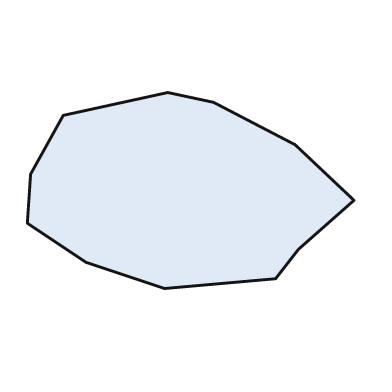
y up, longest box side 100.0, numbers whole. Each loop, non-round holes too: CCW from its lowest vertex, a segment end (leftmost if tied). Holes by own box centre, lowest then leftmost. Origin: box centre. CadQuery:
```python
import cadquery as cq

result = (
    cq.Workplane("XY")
    .moveTo(-8.0, -30.0)
    .lineTo(26.0, -27.0)
    .lineTo(33.0, -18.0)
    .lineTo(50.0, -3.0)
    .lineTo(32.0, 14.0)
    .lineTo(7.0, 27.0)
    .lineTo(-7.0, 30.0)
    .lineTo(-39.0, 23.0)
    .lineTo(-49.0, 5.0)
    .lineTo(-50.0, -10.0)
    .lineTo(-32.0, -22.0)
    .close()
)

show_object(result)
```